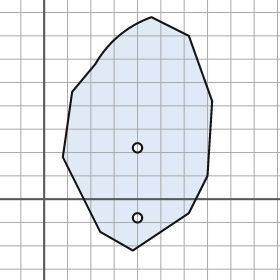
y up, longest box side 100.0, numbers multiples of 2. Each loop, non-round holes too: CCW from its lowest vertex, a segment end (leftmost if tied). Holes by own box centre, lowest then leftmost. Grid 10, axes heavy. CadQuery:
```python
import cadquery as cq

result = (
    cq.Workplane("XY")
    .moveTo(38.0, -22.0)
    .lineTo(62.0, -6.0)
    .lineTo(70.0, 10.0)
    .lineTo(72.0, 42.0)
    .lineTo(62.0, 70.0)
    .lineTo(46.0, 78.0)
    .threePointArc((32.0, 70.0), (22.0, 58.0))
    .lineTo(12.0, 46.0)
    .lineTo(8.0, 18.0)
    .lineTo(24.0, -14.0)
    .close()
    .moveTo(40.0, -8.0)
    .circle(2.0)
    .moveTo(40.0, 22.0)
    .circle(2.0)
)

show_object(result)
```